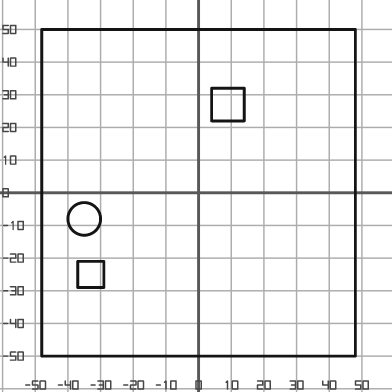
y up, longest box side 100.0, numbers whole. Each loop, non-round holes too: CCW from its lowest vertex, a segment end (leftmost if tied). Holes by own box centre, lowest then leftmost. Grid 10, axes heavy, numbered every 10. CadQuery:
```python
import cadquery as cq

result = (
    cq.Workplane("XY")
    .moveTo(-48.0, -50.0)
    .lineTo(48.0, -50.0)
    .lineTo(48.0, 50.0)
    .lineTo(-48.0, 50.0)
    .close()
    .moveTo(-37.0, -29.0)
    .lineTo(-29.0, -29.0)
    .lineTo(-29.0, -21.0)
    .lineTo(-37.0, -21.0)
    .close()
    .moveTo(-35.0, -8.0)
    .circle(5.0)
    .moveTo(4.0, 22.0)
    .lineTo(14.0, 22.0)
    .lineTo(14.0, 32.0)
    .lineTo(4.0, 32.0)
    .close()
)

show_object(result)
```